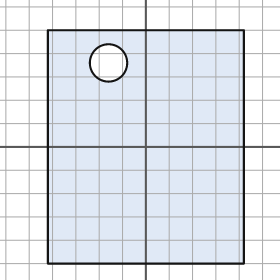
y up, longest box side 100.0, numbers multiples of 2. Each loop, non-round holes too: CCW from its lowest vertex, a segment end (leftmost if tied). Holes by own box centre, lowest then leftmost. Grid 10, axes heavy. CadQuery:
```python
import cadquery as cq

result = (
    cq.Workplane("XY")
    .moveTo(-42.0, -50.0)
    .lineTo(42.0, -50.0)
    .lineTo(42.0, 50.0)
    .lineTo(-42.0, 50.0)
    .close()
    .moveTo(-16.0, 36.0)
    .circle(8.0)
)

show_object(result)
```